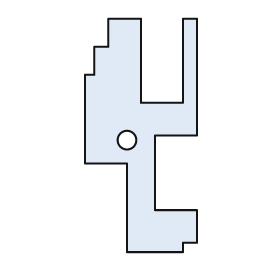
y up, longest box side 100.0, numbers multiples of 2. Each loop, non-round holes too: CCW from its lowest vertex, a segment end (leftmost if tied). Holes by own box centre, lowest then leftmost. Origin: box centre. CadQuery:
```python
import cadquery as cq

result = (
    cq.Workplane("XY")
    .moveTo(-6.0, -50.0)
    .lineTo(18.0, -50.0)
    .lineTo(18.0, -46.0)
    .lineTo(24.0, -46.0)
    .lineTo(24.0, -32.0)
    .lineTo(6.0, -32.0)
    .lineTo(6.0, 0.0)
    .lineTo(24.0, 0.0)
    .lineTo(24.0, 50.0)
    .lineTo(18.0, 50.0)
    .lineTo(18.0, 14.0)
    .lineTo(0.0, 14.0)
    .lineTo(0.0, 50.0)
    .lineTo(-14.0, 50.0)
    .lineTo(-14.0, 38.0)
    .lineTo(-20.0, 38.0)
    .lineTo(-20.0, 26.0)
    .lineTo(-24.0, 26.0)
    .lineTo(-24.0, -12.0)
    .lineTo(-6.0, -12.0)
    .close()
    .moveTo(-6.0, -2.0)
    .circle(4.0)
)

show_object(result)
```